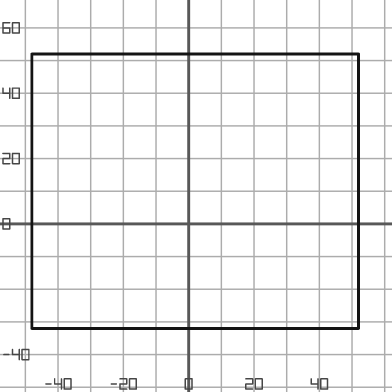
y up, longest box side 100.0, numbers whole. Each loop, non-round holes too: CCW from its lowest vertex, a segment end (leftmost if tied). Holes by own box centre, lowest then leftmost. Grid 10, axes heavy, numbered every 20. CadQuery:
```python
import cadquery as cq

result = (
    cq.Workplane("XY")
    .moveTo(-48.0, -32.0)
    .lineTo(52.0, -32.0)
    .lineTo(52.0, 52.0)
    .lineTo(-48.0, 52.0)
    .close()
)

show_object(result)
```